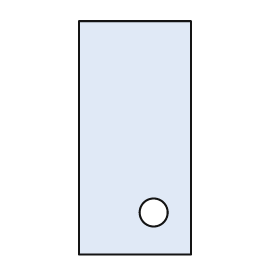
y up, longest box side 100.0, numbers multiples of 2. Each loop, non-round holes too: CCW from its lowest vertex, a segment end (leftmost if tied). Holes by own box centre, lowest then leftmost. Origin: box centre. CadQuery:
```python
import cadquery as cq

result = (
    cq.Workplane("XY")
    .moveTo(-24.0, -50.0)
    .lineTo(24.0, -50.0)
    .lineTo(24.0, 50.0)
    .lineTo(-24.0, 50.0)
    .close()
    .moveTo(8.0, -32.0)
    .circle(6.0)
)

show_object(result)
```